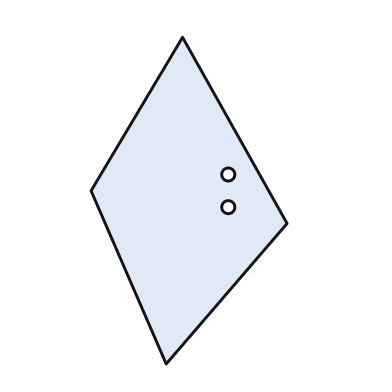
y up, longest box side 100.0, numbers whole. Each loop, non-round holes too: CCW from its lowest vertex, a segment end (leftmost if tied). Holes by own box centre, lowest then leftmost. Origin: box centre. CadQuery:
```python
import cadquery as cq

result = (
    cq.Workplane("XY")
    .moveTo(-7.0, -50.0)
    .lineTo(30.0, -7.0)
    .lineTo(-2.0, 50.0)
    .lineTo(-30.0, 3.0)
    .close()
    .moveTo(12.0, -2.0)
    .circle(2.0)
    .moveTo(12.0, 8.0)
    .circle(2.0)
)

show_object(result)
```